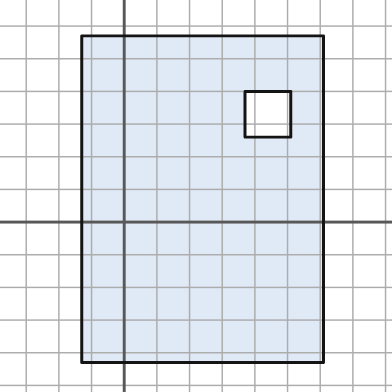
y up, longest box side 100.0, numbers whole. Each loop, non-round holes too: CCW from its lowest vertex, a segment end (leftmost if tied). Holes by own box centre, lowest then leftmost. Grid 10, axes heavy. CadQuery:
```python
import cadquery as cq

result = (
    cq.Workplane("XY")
    .moveTo(-13.0, -43.0)
    .lineTo(61.0, -43.0)
    .lineTo(61.0, 57.0)
    .lineTo(-13.0, 57.0)
    .close()
    .moveTo(37.0, 26.0)
    .lineTo(51.0, 26.0)
    .lineTo(51.0, 40.0)
    .lineTo(37.0, 40.0)
    .close()
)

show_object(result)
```